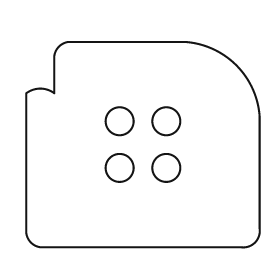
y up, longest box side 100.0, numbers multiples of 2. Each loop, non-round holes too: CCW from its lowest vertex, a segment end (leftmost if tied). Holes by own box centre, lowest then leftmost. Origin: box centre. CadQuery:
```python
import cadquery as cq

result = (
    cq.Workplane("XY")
    .moveTo(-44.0, -44.0)
    .lineTo(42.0, -44.0)
    .threePointArc((48.0, -42.0), (50.0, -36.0))
    .lineTo(50.0, 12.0)
    .threePointArc((40.0, 34.0), (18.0, 44.0))
    .lineTo(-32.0, 44.0)
    .threePointArc((-36.0, 42.0), (-38.0, 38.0))
    .lineTo(-38.0, 22.0)
    .threePointArc((-44.0, 24.0), (-50.0, 22.0))
    .lineTo(-50.0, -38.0)
    .threePointArc((-48.0, -42.0), (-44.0, -44.0))
    .close()
    .moveTo(-10.0, -10.0)
    .circle(6.0)
    .moveTo(10.0, -10.0)
    .circle(6.0)
    .moveTo(-10.0, 10.0)
    .circle(6.0)
    .moveTo(10.0, 10.0)
    .circle(6.0)
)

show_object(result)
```